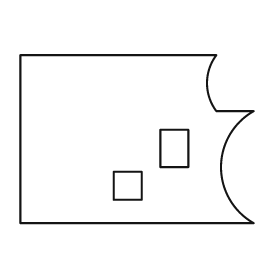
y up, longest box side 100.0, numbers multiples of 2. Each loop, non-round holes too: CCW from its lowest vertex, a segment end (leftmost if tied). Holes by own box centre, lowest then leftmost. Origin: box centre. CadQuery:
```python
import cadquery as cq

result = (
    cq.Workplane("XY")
    .moveTo(-50.0, -36.0)
    .lineTo(50.0, -36.0)
    .threePointArc((36.0, -12.0), (50.0, 12.0))
    .lineTo(34.0, 12.0)
    .threePointArc((30.0, 24.0), (34.0, 36.0))
    .lineTo(-50.0, 36.0)
    .close()
    .moveTo(-10.0, -26.0)
    .lineTo(2.0, -26.0)
    .lineTo(2.0, -14.0)
    .lineTo(-10.0, -14.0)
    .close()
    .moveTo(10.0, -12.0)
    .lineTo(22.0, -12.0)
    .lineTo(22.0, 4.0)
    .lineTo(10.0, 4.0)
    .close()
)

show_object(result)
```